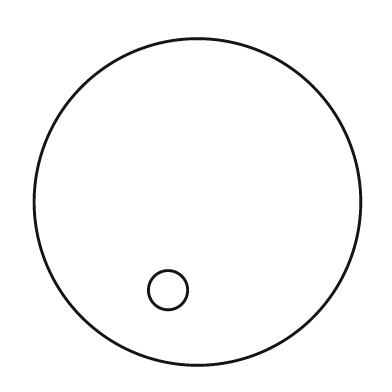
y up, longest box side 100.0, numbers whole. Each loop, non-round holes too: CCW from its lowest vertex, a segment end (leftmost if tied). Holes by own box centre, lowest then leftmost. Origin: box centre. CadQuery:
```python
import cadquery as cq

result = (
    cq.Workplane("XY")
    .moveTo(0.0, 0.0)
    .circle(50.0)
    .moveTo(-9.0, -27.0)
    .circle(6.0)
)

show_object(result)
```